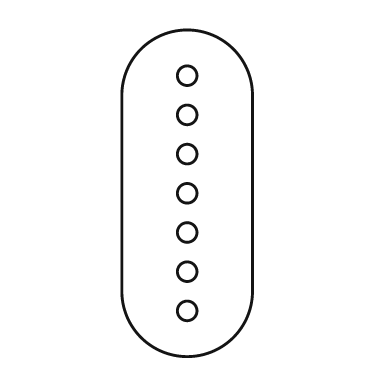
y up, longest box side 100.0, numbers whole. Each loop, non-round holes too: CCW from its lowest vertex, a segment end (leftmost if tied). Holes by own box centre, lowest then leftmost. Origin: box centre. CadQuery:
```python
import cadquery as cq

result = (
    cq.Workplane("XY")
    .moveTo(-20.0, -30.0)
    .threePointArc((0.0, -50.0), (20.0, -30.0))
    .lineTo(20.0, 30.0)
    .threePointArc((0.0, 50.0), (-20.0, 30.0))
    .close()
    .moveTo(0.0, -36.0)
    .circle(3.0)
    .moveTo(0.0, -24.0)
    .circle(3.0)
    .moveTo(0.0, -12.0)
    .circle(3.0)
    .moveTo(0.0, 0.0)
    .circle(3.0)
    .moveTo(0.0, 12.0)
    .circle(3.0)
    .moveTo(0.0, 24.0)
    .circle(3.0)
    .moveTo(0.0, 36.0)
    .circle(3.0)
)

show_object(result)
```